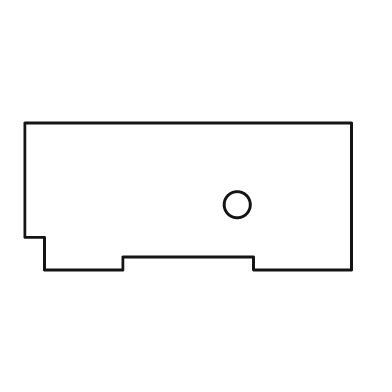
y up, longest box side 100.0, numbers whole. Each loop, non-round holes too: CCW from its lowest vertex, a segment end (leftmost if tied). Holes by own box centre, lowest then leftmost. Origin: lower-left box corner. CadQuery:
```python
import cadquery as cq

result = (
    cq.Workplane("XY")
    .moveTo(6.0, 0.0)
    .lineTo(30.0, 0.0)
    .lineTo(30.0, 4.0)
    .lineTo(70.0, 4.0)
    .lineTo(70.0, 0.0)
    .lineTo(100.0, 0.0)
    .lineTo(100.0, 45.0)
    .lineTo(0.0, 45.0)
    .lineTo(0.0, 10.0)
    .lineTo(6.0, 10.0)
    .close()
    .moveTo(65.0, 20.0)
    .circle(4.0)
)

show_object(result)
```